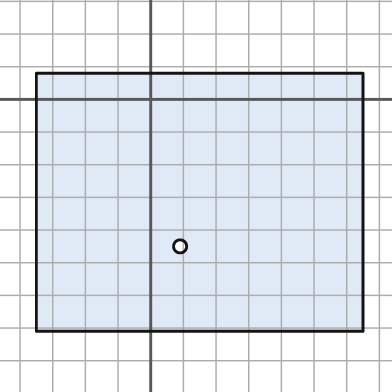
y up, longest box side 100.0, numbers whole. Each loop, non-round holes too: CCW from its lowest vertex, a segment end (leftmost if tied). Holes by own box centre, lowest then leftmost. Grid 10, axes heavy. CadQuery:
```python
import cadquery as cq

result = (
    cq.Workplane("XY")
    .moveTo(-35.0, -71.0)
    .lineTo(65.0, -71.0)
    .lineTo(65.0, 8.0)
    .lineTo(-35.0, 8.0)
    .close()
    .moveTo(9.0, -45.0)
    .circle(2.0)
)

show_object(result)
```